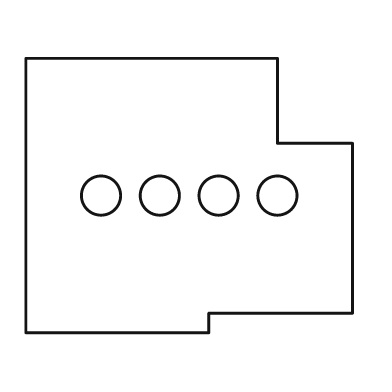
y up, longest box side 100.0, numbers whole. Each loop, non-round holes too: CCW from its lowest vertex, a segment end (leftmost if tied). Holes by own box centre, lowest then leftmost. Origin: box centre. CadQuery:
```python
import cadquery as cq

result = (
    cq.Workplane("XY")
    .moveTo(-50.0, -42.0)
    .lineTo(6.0, -42.0)
    .lineTo(6.0, -36.0)
    .lineTo(50.0, -36.0)
    .lineTo(50.0, 16.0)
    .lineTo(27.0, 16.0)
    .lineTo(27.0, 42.0)
    .lineTo(-50.0, 42.0)
    .close()
    .moveTo(-27.0, 0.0)
    .circle(6.0)
    .moveTo(-9.0, 0.0)
    .circle(6.0)
    .moveTo(9.0, 0.0)
    .circle(6.0)
    .moveTo(27.0, 0.0)
    .circle(6.0)
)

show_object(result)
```